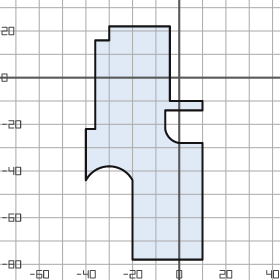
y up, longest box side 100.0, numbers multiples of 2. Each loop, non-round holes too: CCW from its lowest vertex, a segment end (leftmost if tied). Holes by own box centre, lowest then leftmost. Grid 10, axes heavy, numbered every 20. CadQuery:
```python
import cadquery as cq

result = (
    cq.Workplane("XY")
    .moveTo(-20.0, -78.0)
    .lineTo(10.0, -78.0)
    .lineTo(10.0, -28.0)
    .lineTo(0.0, -28.0)
    .threePointArc((-4.0, -26.0), (-6.0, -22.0))
    .lineTo(-6.0, -14.0)
    .lineTo(10.0, -14.0)
    .lineTo(10.0, -10.0)
    .lineTo(-4.0, -10.0)
    .lineTo(-4.0, 22.0)
    .lineTo(-30.0, 22.0)
    .lineTo(-30.0, 16.0)
    .lineTo(-36.0, 16.0)
    .lineTo(-36.0, -22.0)
    .lineTo(-40.0, -22.0)
    .lineTo(-40.0, -44.0)
    .threePointArc((-30.0, -38.0), (-20.0, -44.0))
    .close()
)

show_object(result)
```